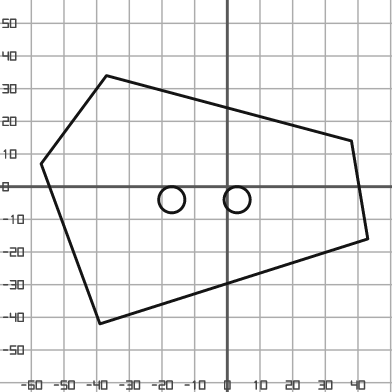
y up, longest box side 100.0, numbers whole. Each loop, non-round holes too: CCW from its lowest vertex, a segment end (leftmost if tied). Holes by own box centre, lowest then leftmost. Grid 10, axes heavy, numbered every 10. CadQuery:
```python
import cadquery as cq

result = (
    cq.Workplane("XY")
    .moveTo(-39.0, -42.0)
    .lineTo(43.0, -16.0)
    .lineTo(38.0, 14.0)
    .lineTo(-37.0, 34.0)
    .lineTo(-57.0, 7.0)
    .close()
    .moveTo(-17.0, -4.0)
    .circle(4.0)
    .moveTo(3.0, -4.0)
    .circle(4.0)
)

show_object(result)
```